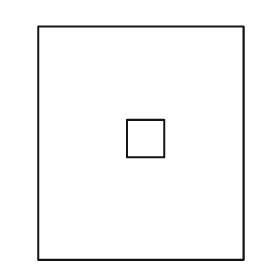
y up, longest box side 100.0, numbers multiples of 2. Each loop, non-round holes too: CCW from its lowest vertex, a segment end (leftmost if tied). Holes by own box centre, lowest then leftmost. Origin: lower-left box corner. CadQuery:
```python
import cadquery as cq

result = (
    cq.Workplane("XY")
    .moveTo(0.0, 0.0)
    .lineTo(88.0, 0.0)
    .lineTo(88.0, 100.0)
    .lineTo(0.0, 100.0)
    .close()
    .moveTo(38.0, 44.0)
    .lineTo(54.0, 44.0)
    .lineTo(54.0, 60.0)
    .lineTo(38.0, 60.0)
    .close()
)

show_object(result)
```